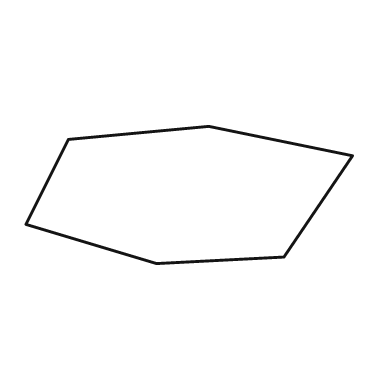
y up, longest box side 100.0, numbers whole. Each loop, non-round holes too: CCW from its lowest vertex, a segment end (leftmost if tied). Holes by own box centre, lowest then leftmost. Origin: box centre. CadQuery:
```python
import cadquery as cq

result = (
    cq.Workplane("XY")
    .moveTo(-10.0, -21.0)
    .lineTo(29.0, -19.0)
    .lineTo(50.0, 12.0)
    .lineTo(6.0, 21.0)
    .lineTo(-37.0, 17.0)
    .lineTo(-50.0, -9.0)
    .close()
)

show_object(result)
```